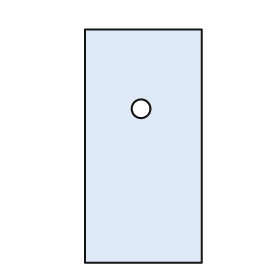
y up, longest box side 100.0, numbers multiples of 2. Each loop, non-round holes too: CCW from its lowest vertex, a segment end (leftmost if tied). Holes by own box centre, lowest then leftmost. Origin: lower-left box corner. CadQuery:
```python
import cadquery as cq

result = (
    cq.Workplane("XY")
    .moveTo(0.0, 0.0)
    .lineTo(50.0, 0.0)
    .lineTo(50.0, 100.0)
    .lineTo(0.0, 100.0)
    .close()
    .moveTo(24.0, 66.0)
    .circle(4.0)
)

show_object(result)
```